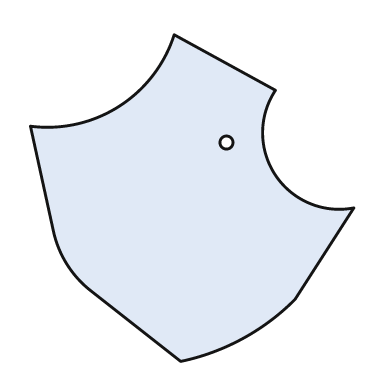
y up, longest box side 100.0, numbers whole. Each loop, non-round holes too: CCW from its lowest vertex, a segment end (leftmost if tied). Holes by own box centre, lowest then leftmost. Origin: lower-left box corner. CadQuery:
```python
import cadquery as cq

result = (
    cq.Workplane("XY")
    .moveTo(46.0, 0.0)
    .threePointArc((65.0, 7.0), (81.0, 19.0))
    .lineTo(99.0, 47.0)
    .threePointArc((75.0, 57.0), (75.0, 83.0))
    .lineTo(44.0, 100.0)
    .threePointArc((27.0, 78.0), (0.0, 72.0))
    .lineTo(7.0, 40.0)
    .threePointArc((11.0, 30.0), (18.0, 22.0))
    .close()
    .moveTo(60.0, 67.0)
    .circle(2.0)
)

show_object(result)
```